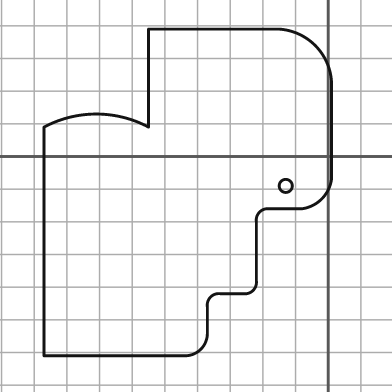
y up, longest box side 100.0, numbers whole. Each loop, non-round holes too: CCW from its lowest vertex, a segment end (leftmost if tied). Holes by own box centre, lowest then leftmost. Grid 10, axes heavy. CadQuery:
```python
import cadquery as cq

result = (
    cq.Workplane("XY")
    .moveTo(-87.0, -61.0)
    .lineTo(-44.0, -61.0)
    .threePointArc((-39.0, -59.0), (-37.0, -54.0))
    .lineTo(-37.0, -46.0)
    .threePointArc((-36.0, -43.0), (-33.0, -42.0))
    .lineTo(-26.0, -42.0)
    .threePointArc((-23.0, -41.0), (-22.0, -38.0))
    .lineTo(-22.0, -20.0)
    .threePointArc((-21.0, -17.0), (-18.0, -16.0))
    .lineTo(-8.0, -16.0)
    .threePointArc((-2.0, -13.0), (1.0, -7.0))
    .lineTo(1.0, 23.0)
    .threePointArc((-4.0, 34.0), (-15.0, 39.0))
    .lineTo(-55.0, 39.0)
    .lineTo(-55.0, 9.0)
    .threePointArc((-71.0, 13.0), (-87.0, 9.0))
    .close()
    .moveTo(-13.0, -9.0)
    .circle(2.0)
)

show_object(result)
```